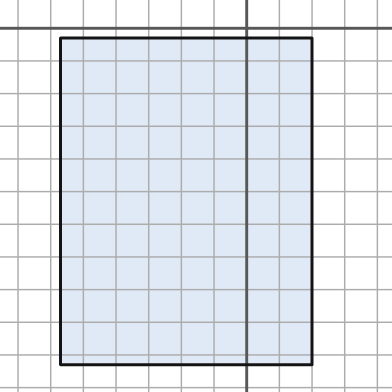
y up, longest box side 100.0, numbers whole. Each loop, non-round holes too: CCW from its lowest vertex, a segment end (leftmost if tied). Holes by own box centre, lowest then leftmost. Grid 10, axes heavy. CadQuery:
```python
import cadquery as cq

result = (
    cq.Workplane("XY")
    .moveTo(-57.0, -103.0)
    .lineTo(20.0, -103.0)
    .lineTo(20.0, -3.0)
    .lineTo(-57.0, -3.0)
    .close()
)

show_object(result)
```